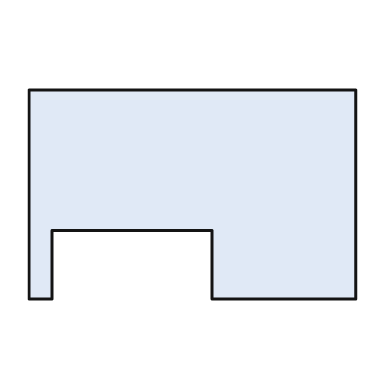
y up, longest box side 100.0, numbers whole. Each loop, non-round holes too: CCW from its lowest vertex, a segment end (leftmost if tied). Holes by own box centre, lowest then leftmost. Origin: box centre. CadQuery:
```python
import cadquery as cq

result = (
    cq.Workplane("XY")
    .moveTo(-50.0, -32.0)
    .lineTo(-43.0, -32.0)
    .lineTo(-43.0, -11.0)
    .lineTo(6.0, -11.0)
    .lineTo(6.0, -32.0)
    .lineTo(50.0, -32.0)
    .lineTo(50.0, 32.0)
    .lineTo(-50.0, 32.0)
    .close()
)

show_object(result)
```